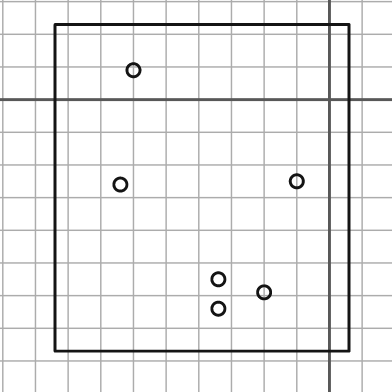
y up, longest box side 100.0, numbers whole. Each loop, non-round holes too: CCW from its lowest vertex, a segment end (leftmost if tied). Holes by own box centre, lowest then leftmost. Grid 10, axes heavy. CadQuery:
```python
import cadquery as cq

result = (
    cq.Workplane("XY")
    .moveTo(-84.0, -77.0)
    .lineTo(6.0, -77.0)
    .lineTo(6.0, 23.0)
    .lineTo(-84.0, 23.0)
    .close()
    .moveTo(-34.0, -64.0)
    .circle(2.0)
    .moveTo(-20.0, -59.0)
    .circle(2.0)
    .moveTo(-34.0, -55.0)
    .circle(2.0)
    .moveTo(-64.0, -26.0)
    .circle(2.0)
    .moveTo(-10.0, -25.0)
    .circle(2.0)
    .moveTo(-60.0, 9.0)
    .circle(2.0)
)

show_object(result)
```